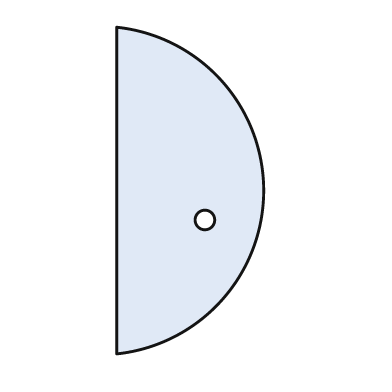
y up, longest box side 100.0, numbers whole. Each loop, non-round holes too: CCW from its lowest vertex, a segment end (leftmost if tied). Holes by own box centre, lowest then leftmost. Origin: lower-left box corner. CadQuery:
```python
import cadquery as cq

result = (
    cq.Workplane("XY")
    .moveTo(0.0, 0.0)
    .threePointArc((45.0, 50.0), (0.0, 100.0))
    .close()
    .moveTo(27.0, 41.0)
    .circle(3.0)
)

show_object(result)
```